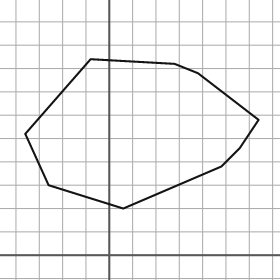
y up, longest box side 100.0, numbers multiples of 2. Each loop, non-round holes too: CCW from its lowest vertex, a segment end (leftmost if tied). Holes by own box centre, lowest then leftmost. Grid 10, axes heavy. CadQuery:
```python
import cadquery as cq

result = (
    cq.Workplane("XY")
    .moveTo(6.0, 20.0)
    .lineTo(48.0, 38.0)
    .lineTo(56.0, 46.0)
    .lineTo(64.0, 58.0)
    .lineTo(38.0, 78.0)
    .lineTo(28.0, 82.0)
    .lineTo(-8.0, 84.0)
    .lineTo(-36.0, 52.0)
    .lineTo(-26.0, 30.0)
    .close()
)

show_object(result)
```